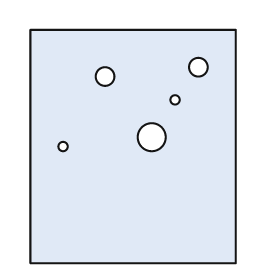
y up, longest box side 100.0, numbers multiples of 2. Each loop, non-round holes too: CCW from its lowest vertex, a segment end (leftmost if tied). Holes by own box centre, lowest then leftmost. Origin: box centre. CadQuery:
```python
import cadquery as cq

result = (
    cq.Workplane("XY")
    .moveTo(-44.0, -50.0)
    .lineTo(44.0, -50.0)
    .lineTo(44.0, 50.0)
    .lineTo(-44.0, 50.0)
    .close()
    .moveTo(-30.0, 0.0)
    .circle(2.0)
    .moveTo(8.0, 4.0)
    .circle(6.0)
    .moveTo(18.0, 20.0)
    .circle(2.0)
    .moveTo(-12.0, 30.0)
    .circle(4.0)
    .moveTo(28.0, 34.0)
    .circle(4.0)
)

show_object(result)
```